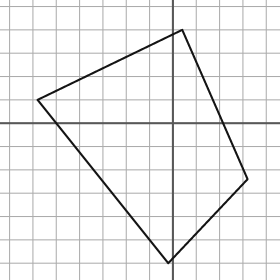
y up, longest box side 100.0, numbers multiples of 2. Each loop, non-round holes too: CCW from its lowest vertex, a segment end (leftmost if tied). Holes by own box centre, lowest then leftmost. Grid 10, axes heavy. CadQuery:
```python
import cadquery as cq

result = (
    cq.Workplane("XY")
    .moveTo(-2.0, -60.0)
    .lineTo(32.0, -24.0)
    .lineTo(4.0, 40.0)
    .lineTo(-58.0, 10.0)
    .close()
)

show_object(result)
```